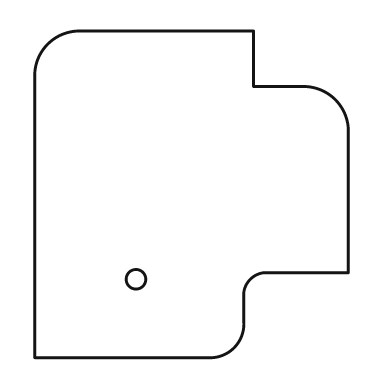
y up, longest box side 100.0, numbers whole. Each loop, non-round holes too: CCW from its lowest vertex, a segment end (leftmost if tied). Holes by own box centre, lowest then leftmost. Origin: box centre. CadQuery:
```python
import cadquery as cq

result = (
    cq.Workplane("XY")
    .moveTo(-48.0, -50.0)
    .lineTo(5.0, -50.0)
    .threePointArc((13.0, -47.0), (16.0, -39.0))
    .lineTo(16.0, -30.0)
    .threePointArc((18.0, -26.0), (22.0, -24.0))
    .lineTo(48.0, -24.0)
    .lineTo(48.0, 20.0)
    .threePointArc((44.0, 29.0), (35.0, 33.0))
    .lineTo(19.0, 33.0)
    .lineTo(19.0, 50.0)
    .lineTo(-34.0, 50.0)
    .threePointArc((-44.0, 46.0), (-48.0, 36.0))
    .close()
    .moveTo(-17.0, -26.0)
    .circle(3.0)
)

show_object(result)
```